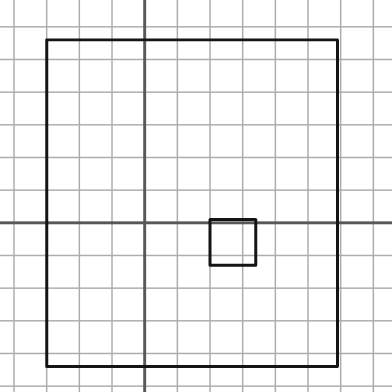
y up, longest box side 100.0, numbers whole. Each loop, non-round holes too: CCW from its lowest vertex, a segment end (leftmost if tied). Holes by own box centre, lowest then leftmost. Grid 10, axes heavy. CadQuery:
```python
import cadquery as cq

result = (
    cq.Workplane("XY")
    .moveTo(-30.0, -44.0)
    .lineTo(59.0, -44.0)
    .lineTo(59.0, 56.0)
    .lineTo(-30.0, 56.0)
    .close()
    .moveTo(20.0, -13.0)
    .lineTo(34.0, -13.0)
    .lineTo(34.0, 1.0)
    .lineTo(20.0, 1.0)
    .close()
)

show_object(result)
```